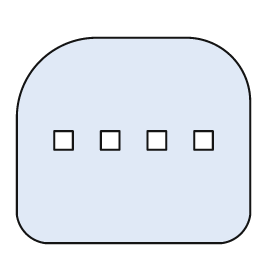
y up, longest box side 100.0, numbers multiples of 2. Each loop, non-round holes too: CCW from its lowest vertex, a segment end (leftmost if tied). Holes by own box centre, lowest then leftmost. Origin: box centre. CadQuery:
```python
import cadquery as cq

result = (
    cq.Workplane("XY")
    .moveTo(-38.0, -44.0)
    .lineTo(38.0, -44.0)
    .threePointArc((46.0, -40.0), (50.0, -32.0))
    .lineTo(50.0, 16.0)
    .threePointArc((42.0, 36.0), (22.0, 44.0))
    .lineTo(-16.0, 44.0)
    .threePointArc((-40.0, 34.0), (-50.0, 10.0))
    .lineTo(-50.0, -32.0)
    .threePointArc((-46.0, -40.0), (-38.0, -44.0))
    .close()
    .moveTo(-34.0, -4.0)
    .lineTo(-26.0, -4.0)
    .lineTo(-26.0, 4.0)
    .lineTo(-34.0, 4.0)
    .close()
    .moveTo(-14.0, -4.0)
    .lineTo(-6.0, -4.0)
    .lineTo(-6.0, 4.0)
    .lineTo(-14.0, 4.0)
    .close()
    .moveTo(6.0, -4.0)
    .lineTo(14.0, -4.0)
    .lineTo(14.0, 4.0)
    .lineTo(6.0, 4.0)
    .close()
    .moveTo(26.0, -4.0)
    .lineTo(34.0, -4.0)
    .lineTo(34.0, 4.0)
    .lineTo(26.0, 4.0)
    .close()
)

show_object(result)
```